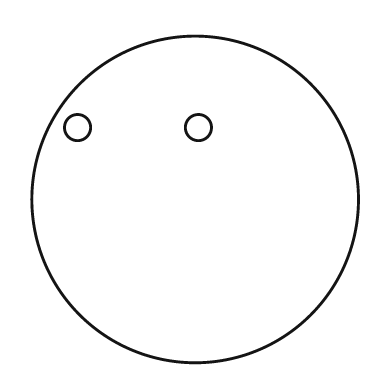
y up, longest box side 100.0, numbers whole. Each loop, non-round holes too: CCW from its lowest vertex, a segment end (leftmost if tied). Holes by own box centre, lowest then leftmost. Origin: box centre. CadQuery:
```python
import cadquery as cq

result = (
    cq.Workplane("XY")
    .moveTo(0.0, 0.0)
    .circle(50.0)
    .moveTo(-36.0, 22.0)
    .circle(4.0)
    .moveTo(1.0, 22.0)
    .circle(4.0)
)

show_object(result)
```